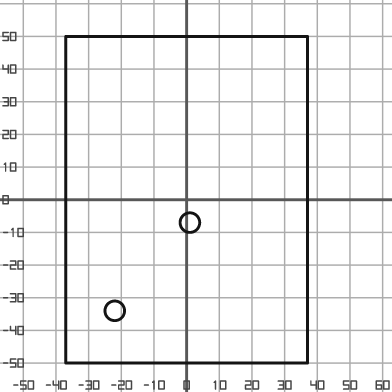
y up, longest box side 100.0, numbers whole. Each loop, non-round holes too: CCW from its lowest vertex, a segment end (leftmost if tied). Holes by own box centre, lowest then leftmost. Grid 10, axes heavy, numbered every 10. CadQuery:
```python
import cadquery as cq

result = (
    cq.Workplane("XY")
    .moveTo(-37.0, -50.0)
    .lineTo(37.0, -50.0)
    .lineTo(37.0, 50.0)
    .lineTo(-37.0, 50.0)
    .close()
    .moveTo(-22.0, -34.0)
    .circle(3.0)
    .moveTo(1.0, -7.0)
    .circle(3.0)
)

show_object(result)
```